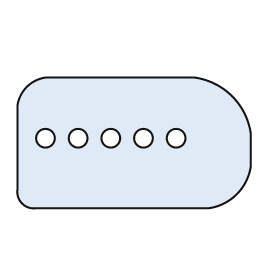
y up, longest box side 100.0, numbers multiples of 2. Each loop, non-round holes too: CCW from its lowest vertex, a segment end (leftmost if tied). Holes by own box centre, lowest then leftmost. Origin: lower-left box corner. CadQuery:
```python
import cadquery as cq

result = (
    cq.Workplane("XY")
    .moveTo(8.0, 0.0)
    .lineTo(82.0, 0.0)
    .threePointArc((94.0, 6.0), (100.0, 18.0))
    .lineTo(100.0, 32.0)
    .threePointArc((92.0, 48.0), (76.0, 56.0))
    .lineTo(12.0, 56.0)
    .threePointArc((4.0, 52.0), (0.0, 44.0))
    .lineTo(0.0, 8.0)
    .threePointArc((2.0, 2.0), (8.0, 0.0))
    .close()
    .moveTo(12.0, 30.0)
    .circle(4.0)
    .moveTo(26.0, 30.0)
    .circle(4.0)
    .moveTo(40.0, 30.0)
    .circle(4.0)
    .moveTo(54.0, 30.0)
    .circle(4.0)
    .moveTo(68.0, 30.0)
    .circle(4.0)
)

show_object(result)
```